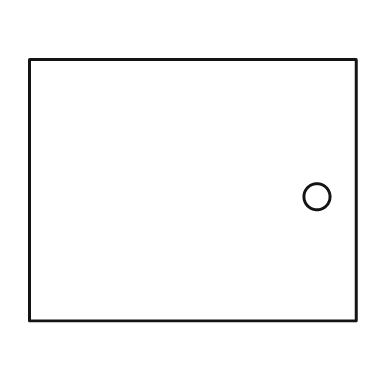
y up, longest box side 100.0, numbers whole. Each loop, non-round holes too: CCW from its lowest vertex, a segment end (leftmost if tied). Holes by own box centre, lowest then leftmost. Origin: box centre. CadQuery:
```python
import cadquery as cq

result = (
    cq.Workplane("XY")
    .moveTo(-50.0, -40.0)
    .lineTo(50.0, -40.0)
    .lineTo(50.0, 40.0)
    .lineTo(-50.0, 40.0)
    .close()
    .moveTo(38.0, -2.0)
    .circle(4.0)
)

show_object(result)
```